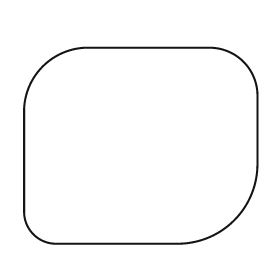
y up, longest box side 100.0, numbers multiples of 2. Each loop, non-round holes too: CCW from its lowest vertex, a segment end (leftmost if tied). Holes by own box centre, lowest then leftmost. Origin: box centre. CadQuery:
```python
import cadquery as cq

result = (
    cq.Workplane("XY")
    .moveTo(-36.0, -42.0)
    .lineTo(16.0, -42.0)
    .threePointArc((40.0, -32.0), (50.0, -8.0))
    .lineTo(50.0, 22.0)
    .threePointArc((44.0, 36.0), (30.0, 42.0))
    .lineTo(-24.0, 42.0)
    .threePointArc((-42.0, 34.0), (-50.0, 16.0))
    .lineTo(-50.0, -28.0)
    .threePointArc((-46.0, -38.0), (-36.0, -42.0))
    .close()
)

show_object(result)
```